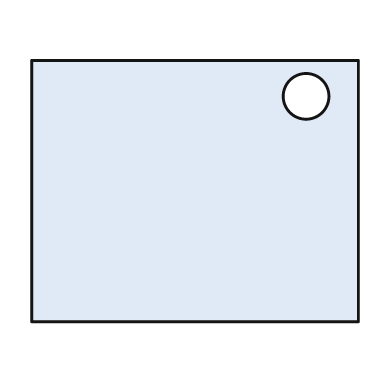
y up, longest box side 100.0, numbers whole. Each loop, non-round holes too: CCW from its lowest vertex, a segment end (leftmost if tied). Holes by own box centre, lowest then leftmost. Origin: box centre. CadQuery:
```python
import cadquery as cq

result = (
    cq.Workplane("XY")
    .moveTo(-50.0, -40.0)
    .lineTo(50.0, -40.0)
    .lineTo(50.0, 40.0)
    .lineTo(-50.0, 40.0)
    .close()
    .moveTo(34.0, 29.0)
    .circle(7.0)
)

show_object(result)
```